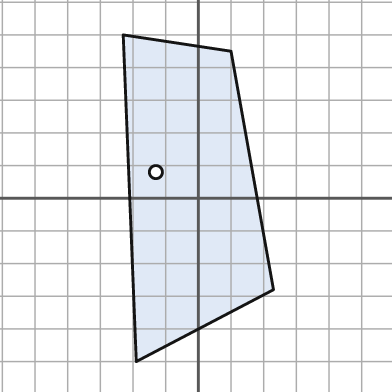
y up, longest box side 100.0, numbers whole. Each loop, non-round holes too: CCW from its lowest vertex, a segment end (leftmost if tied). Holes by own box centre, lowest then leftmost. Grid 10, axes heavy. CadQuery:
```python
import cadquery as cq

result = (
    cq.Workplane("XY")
    .moveTo(-19.0, -50.0)
    .lineTo(23.0, -28.0)
    .lineTo(10.0, 45.0)
    .lineTo(-23.0, 50.0)
    .close()
    .moveTo(-13.0, 8.0)
    .circle(2.0)
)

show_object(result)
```